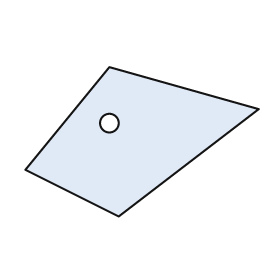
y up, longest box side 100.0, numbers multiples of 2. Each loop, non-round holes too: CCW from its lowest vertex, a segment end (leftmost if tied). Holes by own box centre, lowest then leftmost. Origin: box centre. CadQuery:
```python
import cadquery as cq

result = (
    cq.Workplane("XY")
    .moveTo(-10.0, -32.0)
    .lineTo(50.0, 14.0)
    .lineTo(-14.0, 32.0)
    .lineTo(-50.0, -12.0)
    .close()
    .moveTo(-14.0, 8.0)
    .circle(4.0)
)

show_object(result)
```